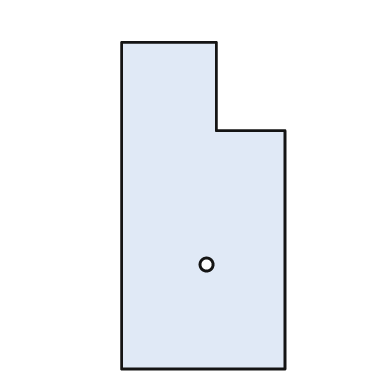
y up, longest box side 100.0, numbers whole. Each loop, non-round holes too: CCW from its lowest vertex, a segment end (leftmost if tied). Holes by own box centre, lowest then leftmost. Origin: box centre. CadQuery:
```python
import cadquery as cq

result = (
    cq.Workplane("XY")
    .moveTo(-25.0, -50.0)
    .lineTo(25.0, -50.0)
    .lineTo(25.0, 23.0)
    .lineTo(4.0, 23.0)
    .lineTo(4.0, 50.0)
    .lineTo(-25.0, 50.0)
    .close()
    .moveTo(1.0, -18.0)
    .circle(2.0)
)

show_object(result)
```